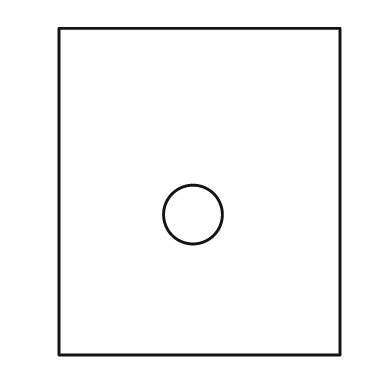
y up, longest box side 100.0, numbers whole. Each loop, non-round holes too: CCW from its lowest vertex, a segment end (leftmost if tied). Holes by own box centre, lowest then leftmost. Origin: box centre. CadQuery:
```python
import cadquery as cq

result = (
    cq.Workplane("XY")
    .moveTo(-43.0, -50.0)
    .lineTo(43.0, -50.0)
    .lineTo(43.0, 50.0)
    .lineTo(-43.0, 50.0)
    .close()
    .moveTo(-2.0, -7.0)
    .circle(9.0)
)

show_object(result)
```